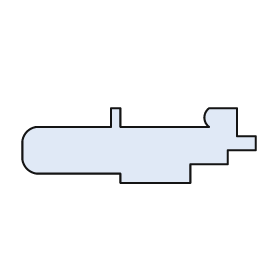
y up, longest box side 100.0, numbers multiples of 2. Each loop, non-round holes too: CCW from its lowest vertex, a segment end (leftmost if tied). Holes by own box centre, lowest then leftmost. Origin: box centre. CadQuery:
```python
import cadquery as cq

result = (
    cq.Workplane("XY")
    .moveTo(-8.0, -16.0)
    .lineTo(22.0, -16.0)
    .lineTo(22.0, -8.0)
    .lineTo(38.0, -8.0)
    .lineTo(38.0, -2.0)
    .lineTo(50.0, -2.0)
    .lineTo(50.0, 4.0)
    .lineTo(42.0, 4.0)
    .lineTo(42.0, 16.0)
    .lineTo(30.0, 16.0)
    .threePointArc((28.0, 12.0), (30.0, 8.0))
    .lineTo(-8.0, 8.0)
    .lineTo(-8.0, 16.0)
    .lineTo(-12.0, 16.0)
    .lineTo(-12.0, 8.0)
    .lineTo(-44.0, 8.0)
    .threePointArc((-48.0, 6.0), (-50.0, 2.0))
    .lineTo(-50.0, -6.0)
    .threePointArc((-48.0, -10.0), (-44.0, -12.0))
    .lineTo(-8.0, -12.0)
    .close()
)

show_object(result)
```